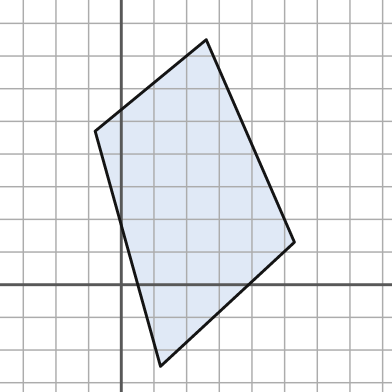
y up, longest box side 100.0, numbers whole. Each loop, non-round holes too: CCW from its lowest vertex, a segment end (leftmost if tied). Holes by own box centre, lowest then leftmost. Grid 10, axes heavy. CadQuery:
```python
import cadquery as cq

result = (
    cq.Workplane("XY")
    .moveTo(12.0, -25.0)
    .lineTo(53.0, 13.0)
    .lineTo(26.0, 75.0)
    .lineTo(-8.0, 47.0)
    .close()
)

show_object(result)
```